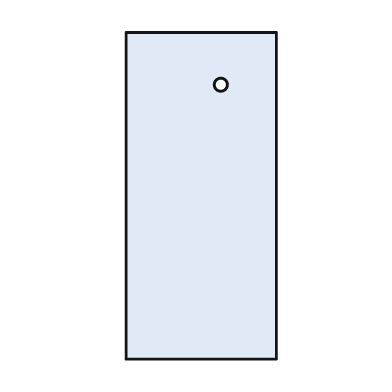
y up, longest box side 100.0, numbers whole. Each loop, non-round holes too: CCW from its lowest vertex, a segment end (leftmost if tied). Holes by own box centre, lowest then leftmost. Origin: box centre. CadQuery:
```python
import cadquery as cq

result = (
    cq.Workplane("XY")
    .moveTo(-23.0, -50.0)
    .lineTo(23.0, -50.0)
    .lineTo(23.0, 50.0)
    .lineTo(-23.0, 50.0)
    .close()
    .moveTo(6.0, 34.0)
    .circle(2.0)
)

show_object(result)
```